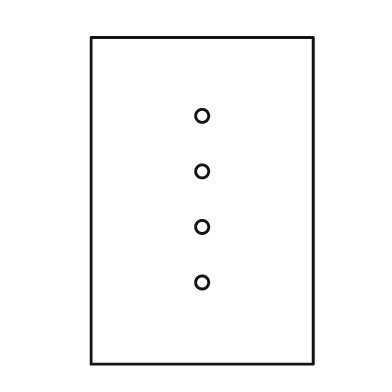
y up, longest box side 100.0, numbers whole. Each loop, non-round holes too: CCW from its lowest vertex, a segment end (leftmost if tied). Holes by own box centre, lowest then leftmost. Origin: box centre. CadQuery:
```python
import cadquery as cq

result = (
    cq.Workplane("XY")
    .moveTo(-34.0, -50.0)
    .lineTo(34.0, -50.0)
    .lineTo(34.0, 50.0)
    .lineTo(-34.0, 50.0)
    .close()
    .moveTo(0.0, -25.0)
    .circle(2.0)
    .moveTo(0.0, -8.0)
    .circle(2.0)
    .moveTo(0.0, 9.0)
    .circle(2.0)
    .moveTo(0.0, 26.0)
    .circle(2.0)
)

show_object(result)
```